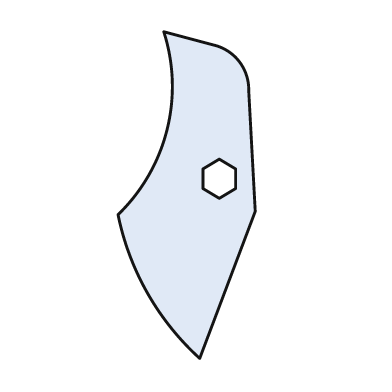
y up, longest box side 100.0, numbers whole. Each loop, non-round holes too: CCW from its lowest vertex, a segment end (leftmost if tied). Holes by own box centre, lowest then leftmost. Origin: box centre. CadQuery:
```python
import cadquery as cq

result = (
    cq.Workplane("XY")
    .moveTo(4.0, -50.0)
    .lineTo(21.0, -5.0)
    .lineTo(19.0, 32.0)
    .threePointArc((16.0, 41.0), (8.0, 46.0))
    .lineTo(-7.0, 50.0)
    .threePointArc((-6.0, 20.0), (-21.0, -6.0))
    .threePointArc((-12.0, -30.0), (4.0, -50.0))
    .close()
    .moveTo(10.0, -1.0)
    .lineTo(15.0, 2.0)
    .lineTo(15.0, 8.0)
    .lineTo(10.0, 11.0)
    .lineTo(5.0, 8.0)
    .lineTo(5.0, 2.0)
    .close()
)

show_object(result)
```